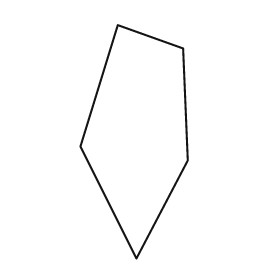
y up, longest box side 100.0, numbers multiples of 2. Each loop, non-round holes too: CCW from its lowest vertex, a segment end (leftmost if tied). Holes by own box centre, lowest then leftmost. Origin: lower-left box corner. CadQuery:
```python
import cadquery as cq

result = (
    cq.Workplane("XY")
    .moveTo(24.0, 0.0)
    .lineTo(46.0, 42.0)
    .lineTo(44.0, 90.0)
    .lineTo(16.0, 100.0)
    .lineTo(0.0, 48.0)
    .close()
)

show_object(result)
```